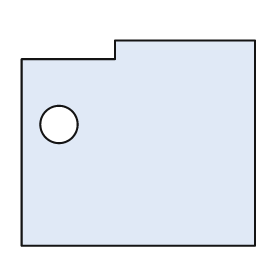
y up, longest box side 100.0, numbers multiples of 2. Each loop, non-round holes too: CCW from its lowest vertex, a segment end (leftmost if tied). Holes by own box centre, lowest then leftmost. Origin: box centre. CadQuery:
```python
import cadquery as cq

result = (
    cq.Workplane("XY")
    .moveTo(-50.0, -44.0)
    .lineTo(50.0, -44.0)
    .lineTo(50.0, 44.0)
    .lineTo(-10.0, 44.0)
    .lineTo(-10.0, 36.0)
    .lineTo(-50.0, 36.0)
    .close()
    .moveTo(-34.0, 8.0)
    .circle(8.0)
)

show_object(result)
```